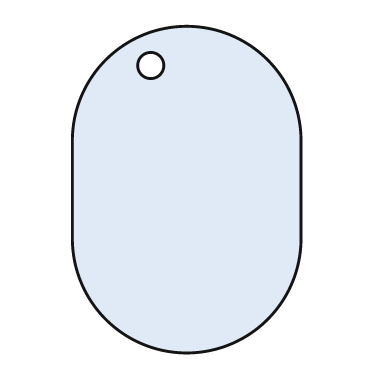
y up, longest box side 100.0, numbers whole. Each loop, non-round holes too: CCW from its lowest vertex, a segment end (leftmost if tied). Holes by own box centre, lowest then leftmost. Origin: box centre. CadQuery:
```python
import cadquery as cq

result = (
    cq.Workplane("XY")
    .moveTo(-35.0, -15.0)
    .threePointArc((0.0, -50.0), (35.0, -15.0))
    .lineTo(35.0, 15.0)
    .threePointArc((0.0, 50.0), (-35.0, 15.0))
    .close()
    .moveTo(-11.0, 38.0)
    .circle(4.0)
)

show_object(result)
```